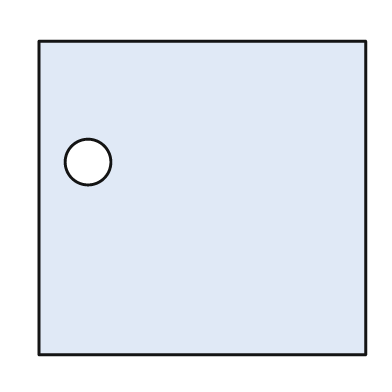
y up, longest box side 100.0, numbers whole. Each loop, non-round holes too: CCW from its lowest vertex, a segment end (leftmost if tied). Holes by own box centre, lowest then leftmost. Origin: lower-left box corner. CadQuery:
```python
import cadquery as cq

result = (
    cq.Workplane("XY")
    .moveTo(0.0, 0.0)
    .lineTo(100.0, 0.0)
    .lineTo(100.0, 96.0)
    .lineTo(0.0, 96.0)
    .close()
    .moveTo(15.0, 59.0)
    .circle(7.0)
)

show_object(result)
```